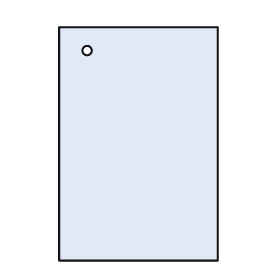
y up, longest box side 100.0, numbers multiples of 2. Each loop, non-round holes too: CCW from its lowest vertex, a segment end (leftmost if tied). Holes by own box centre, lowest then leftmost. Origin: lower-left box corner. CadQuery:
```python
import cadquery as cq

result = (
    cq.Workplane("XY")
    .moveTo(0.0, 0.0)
    .lineTo(68.0, 0.0)
    .lineTo(68.0, 100.0)
    .lineTo(0.0, 100.0)
    .close()
    .moveTo(12.0, 90.0)
    .circle(2.0)
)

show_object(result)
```